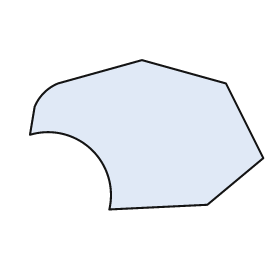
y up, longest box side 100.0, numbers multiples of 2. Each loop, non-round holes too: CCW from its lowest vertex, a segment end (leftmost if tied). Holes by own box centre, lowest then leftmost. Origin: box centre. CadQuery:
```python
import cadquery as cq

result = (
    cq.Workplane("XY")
    .moveTo(-16.0, -32.0)
    .lineTo(26.0, -30.0)
    .lineTo(50.0, -10.0)
    .lineTo(34.0, 22.0)
    .lineTo(-2.0, 32.0)
    .lineTo(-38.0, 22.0)
    .threePointArc((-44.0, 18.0), (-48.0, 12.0))
    .lineTo(-50.0, 0.0)
    .threePointArc((-24.0, -6.0), (-16.0, -32.0))
    .close()
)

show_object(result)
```